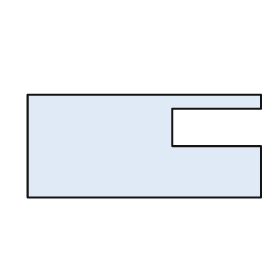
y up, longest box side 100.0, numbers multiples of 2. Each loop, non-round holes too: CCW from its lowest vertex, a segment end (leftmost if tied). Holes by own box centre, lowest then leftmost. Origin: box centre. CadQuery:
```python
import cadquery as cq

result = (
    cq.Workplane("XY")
    .moveTo(-50.0, -22.0)
    .lineTo(50.0, -22.0)
    .lineTo(50.0, 0.0)
    .lineTo(12.0, 0.0)
    .lineTo(12.0, 16.0)
    .lineTo(50.0, 16.0)
    .lineTo(50.0, 22.0)
    .lineTo(-50.0, 22.0)
    .close()
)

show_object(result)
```